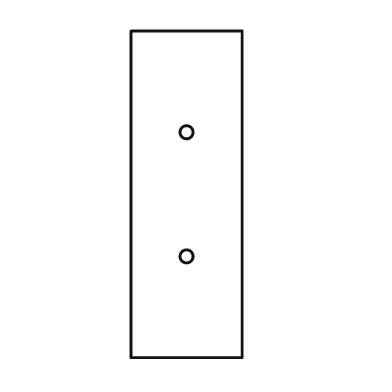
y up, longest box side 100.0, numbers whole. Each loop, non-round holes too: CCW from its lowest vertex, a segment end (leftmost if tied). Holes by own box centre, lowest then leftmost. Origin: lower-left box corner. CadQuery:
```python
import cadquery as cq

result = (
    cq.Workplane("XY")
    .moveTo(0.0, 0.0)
    .lineTo(34.0, 0.0)
    .lineTo(34.0, 100.0)
    .lineTo(0.0, 100.0)
    .close()
    .moveTo(17.0, 31.0)
    .circle(2.0)
    .moveTo(17.0, 69.0)
    .circle(2.0)
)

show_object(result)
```